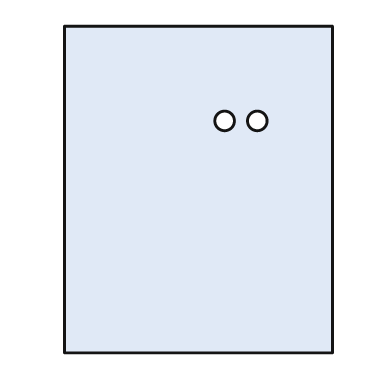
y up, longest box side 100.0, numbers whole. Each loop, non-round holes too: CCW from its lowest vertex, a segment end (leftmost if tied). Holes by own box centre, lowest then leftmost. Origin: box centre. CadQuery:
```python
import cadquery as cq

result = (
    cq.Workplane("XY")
    .moveTo(-41.0, -50.0)
    .lineTo(41.0, -50.0)
    .lineTo(41.0, 50.0)
    .lineTo(-41.0, 50.0)
    .close()
    .moveTo(8.0, 21.0)
    .circle(3.0)
    .moveTo(18.0, 21.0)
    .circle(3.0)
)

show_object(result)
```